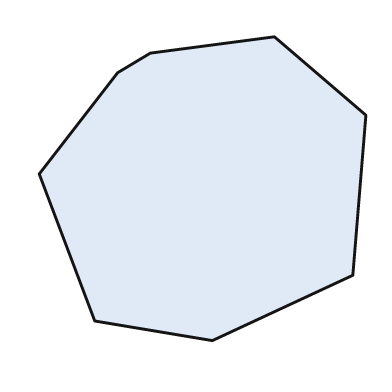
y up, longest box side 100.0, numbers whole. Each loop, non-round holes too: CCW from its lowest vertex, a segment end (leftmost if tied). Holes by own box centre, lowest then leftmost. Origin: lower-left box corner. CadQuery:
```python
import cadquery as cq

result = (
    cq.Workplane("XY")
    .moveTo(53.0, 0.0)
    .lineTo(96.0, 20.0)
    .lineTo(100.0, 69.0)
    .lineTo(72.0, 93.0)
    .lineTo(34.0, 88.0)
    .lineTo(24.0, 82.0)
    .lineTo(0.0, 51.0)
    .lineTo(17.0, 6.0)
    .close()
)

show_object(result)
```